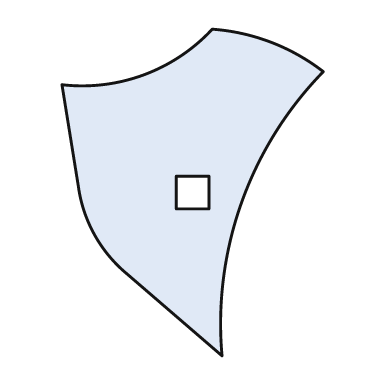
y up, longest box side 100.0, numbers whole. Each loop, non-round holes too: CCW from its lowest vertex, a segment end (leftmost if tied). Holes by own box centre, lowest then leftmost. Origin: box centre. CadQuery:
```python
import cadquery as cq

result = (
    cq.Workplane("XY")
    .moveTo(9.0, -50.0)
    .threePointArc((15.0, -3.0), (40.0, 37.0))
    .threePointArc((24.0, 46.0), (6.0, 50.0))
    .threePointArc((-15.0, 36.0), (-40.0, 33.0))
    .lineTo(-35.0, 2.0)
    .threePointArc((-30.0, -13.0), (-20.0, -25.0))
    .close()
    .moveTo(-5.0, -5.0)
    .lineTo(5.0, -5.0)
    .lineTo(5.0, 5.0)
    .lineTo(-5.0, 5.0)
    .close()
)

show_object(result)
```